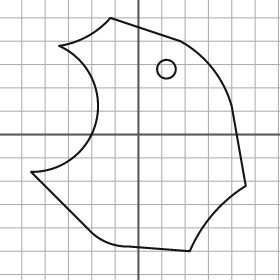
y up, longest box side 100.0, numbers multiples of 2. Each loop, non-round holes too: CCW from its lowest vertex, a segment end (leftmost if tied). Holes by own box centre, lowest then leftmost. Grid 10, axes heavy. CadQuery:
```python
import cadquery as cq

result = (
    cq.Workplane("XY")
    .moveTo(22.0, -50.0)
    .threePointArc((32.0, -34.0), (46.0, -22.0))
    .lineTo(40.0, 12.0)
    .threePointArc((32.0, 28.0), (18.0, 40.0))
    .lineTo(-12.0, 50.0)
    .threePointArc((-22.0, 42.0), (-34.0, 38.0))
    .threePointArc((-18.0, 6.0), (-46.0, -16.0))
    .lineTo(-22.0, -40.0)
    .threePointArc((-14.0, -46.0), (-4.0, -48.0))
    .close()
    .moveTo(12.0, 28.0)
    .circle(4.0)
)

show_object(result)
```